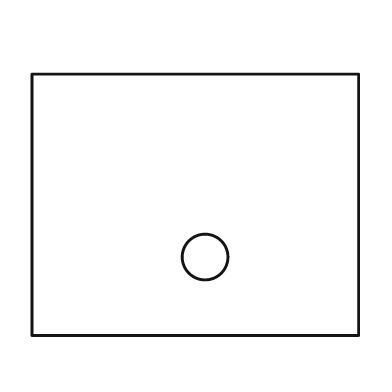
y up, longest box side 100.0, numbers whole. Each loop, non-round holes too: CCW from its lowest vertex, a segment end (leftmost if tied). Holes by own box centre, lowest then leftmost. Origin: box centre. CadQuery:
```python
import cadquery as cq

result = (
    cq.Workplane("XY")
    .moveTo(-50.0, -40.0)
    .lineTo(50.0, -40.0)
    .lineTo(50.0, 40.0)
    .lineTo(-50.0, 40.0)
    .close()
    .moveTo(3.0, -16.0)
    .circle(7.0)
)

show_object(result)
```